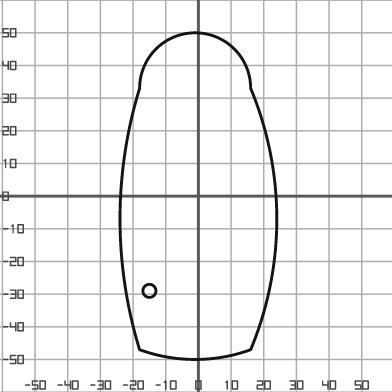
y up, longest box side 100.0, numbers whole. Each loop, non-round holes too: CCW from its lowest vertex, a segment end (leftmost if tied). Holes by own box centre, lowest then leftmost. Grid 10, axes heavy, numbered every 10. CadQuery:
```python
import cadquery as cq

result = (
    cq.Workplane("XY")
    .moveTo(-18.0, -47.0)
    .threePointArc((-1.0, -50.0), (16.0, -47.0))
    .threePointArc((24.0, -7.0), (16.0, 33.0))
    .threePointArc((-1.0, 50.0), (-18.0, 33.0))
    .threePointArc((-24.0, -7.0), (-18.0, -47.0))
    .close()
    .moveTo(-15.0, -29.0)
    .circle(2.0)
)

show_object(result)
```